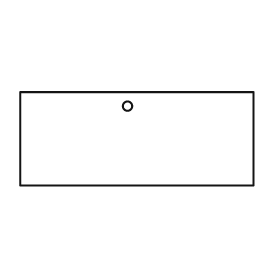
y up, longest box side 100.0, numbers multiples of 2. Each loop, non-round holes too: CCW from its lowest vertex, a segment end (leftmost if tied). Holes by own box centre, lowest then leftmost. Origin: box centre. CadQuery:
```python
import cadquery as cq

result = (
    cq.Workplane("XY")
    .moveTo(-50.0, -20.0)
    .lineTo(50.0, -20.0)
    .lineTo(50.0, 20.0)
    .lineTo(-50.0, 20.0)
    .close()
    .moveTo(-4.0, 14.0)
    .circle(2.0)
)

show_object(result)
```